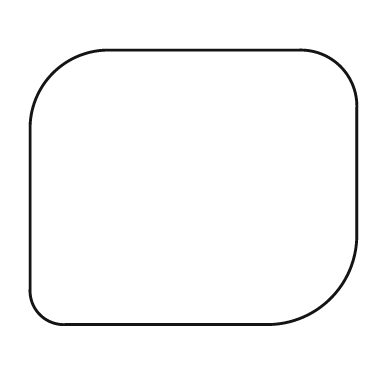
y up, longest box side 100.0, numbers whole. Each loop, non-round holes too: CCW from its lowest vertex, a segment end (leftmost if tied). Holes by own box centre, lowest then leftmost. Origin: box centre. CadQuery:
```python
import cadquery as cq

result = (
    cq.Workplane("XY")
    .moveTo(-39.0, -42.0)
    .lineTo(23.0, -42.0)
    .threePointArc((42.0, -34.0), (50.0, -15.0))
    .lineTo(50.0, 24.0)
    .threePointArc((45.0, 37.0), (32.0, 42.0))
    .lineTo(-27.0, 42.0)
    .threePointArc((-43.0, 35.0), (-50.0, 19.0))
    .lineTo(-50.0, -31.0)
    .threePointArc((-47.0, -39.0), (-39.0, -42.0))
    .close()
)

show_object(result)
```